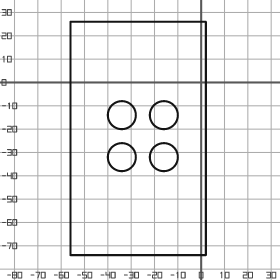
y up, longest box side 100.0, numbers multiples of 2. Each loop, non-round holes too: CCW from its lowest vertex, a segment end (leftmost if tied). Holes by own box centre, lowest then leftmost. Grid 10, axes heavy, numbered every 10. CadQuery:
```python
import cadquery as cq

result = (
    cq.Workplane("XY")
    .moveTo(-56.0, -74.0)
    .lineTo(2.0, -74.0)
    .lineTo(2.0, 26.0)
    .lineTo(-56.0, 26.0)
    .close()
    .moveTo(-34.0, -32.0)
    .circle(6.0)
    .moveTo(-16.0, -32.0)
    .circle(6.0)
    .moveTo(-34.0, -14.0)
    .circle(6.0)
    .moveTo(-16.0, -14.0)
    .circle(6.0)
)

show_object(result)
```